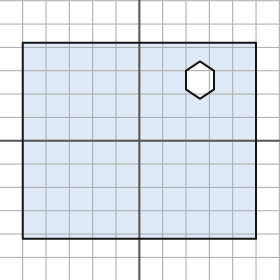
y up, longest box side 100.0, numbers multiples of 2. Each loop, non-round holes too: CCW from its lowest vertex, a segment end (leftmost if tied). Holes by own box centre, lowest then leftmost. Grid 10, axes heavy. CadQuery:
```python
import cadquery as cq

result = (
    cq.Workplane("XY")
    .moveTo(-50.0, -42.0)
    .lineTo(50.0, -42.0)
    .lineTo(50.0, 42.0)
    .lineTo(-50.0, 42.0)
    .close()
    .moveTo(26.0, 18.0)
    .lineTo(32.0, 22.0)
    .lineTo(32.0, 30.0)
    .lineTo(26.0, 34.0)
    .lineTo(20.0, 30.0)
    .lineTo(20.0, 22.0)
    .close()
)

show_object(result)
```